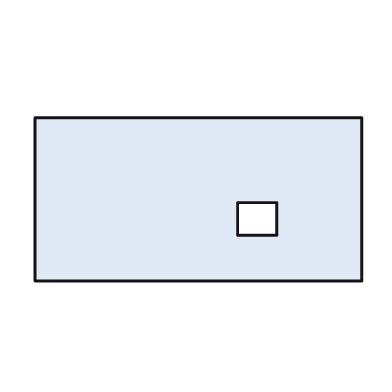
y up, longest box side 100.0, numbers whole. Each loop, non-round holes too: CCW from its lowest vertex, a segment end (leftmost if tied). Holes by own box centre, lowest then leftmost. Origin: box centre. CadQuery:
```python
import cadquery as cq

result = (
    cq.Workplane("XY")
    .moveTo(-50.0, -25.0)
    .lineTo(50.0, -25.0)
    .lineTo(50.0, 25.0)
    .lineTo(-50.0, 25.0)
    .close()
    .moveTo(12.0, -11.0)
    .lineTo(24.0, -11.0)
    .lineTo(24.0, -1.0)
    .lineTo(12.0, -1.0)
    .close()
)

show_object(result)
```